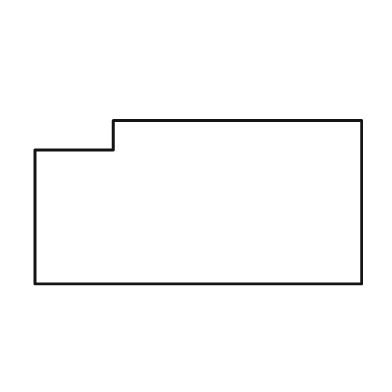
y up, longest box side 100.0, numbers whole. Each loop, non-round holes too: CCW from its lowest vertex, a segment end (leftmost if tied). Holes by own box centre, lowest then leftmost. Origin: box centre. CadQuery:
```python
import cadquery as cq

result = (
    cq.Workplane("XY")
    .moveTo(-50.0, -25.0)
    .lineTo(50.0, -25.0)
    .lineTo(50.0, 25.0)
    .lineTo(-26.0, 25.0)
    .lineTo(-26.0, 16.0)
    .lineTo(-50.0, 16.0)
    .close()
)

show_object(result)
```